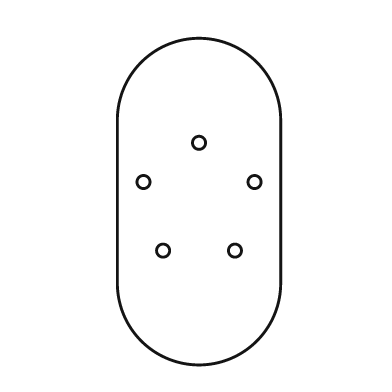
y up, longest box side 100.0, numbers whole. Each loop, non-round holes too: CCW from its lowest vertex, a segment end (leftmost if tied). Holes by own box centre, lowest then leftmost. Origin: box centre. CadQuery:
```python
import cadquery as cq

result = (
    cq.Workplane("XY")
    .moveTo(-25.0, -25.0)
    .threePointArc((0.0, -50.0), (25.0, -25.0))
    .lineTo(25.0, 25.0)
    .threePointArc((0.0, 50.0), (-25.0, 25.0))
    .close()
    .moveTo(-11.0, -15.0)
    .circle(2.0)
    .moveTo(11.0, -15.0)
    .circle(2.0)
    .moveTo(-17.0, 6.0)
    .circle(2.0)
    .moveTo(17.0, 6.0)
    .circle(2.0)
    .moveTo(0.0, 18.0)
    .circle(2.0)
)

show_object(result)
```